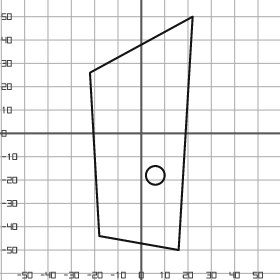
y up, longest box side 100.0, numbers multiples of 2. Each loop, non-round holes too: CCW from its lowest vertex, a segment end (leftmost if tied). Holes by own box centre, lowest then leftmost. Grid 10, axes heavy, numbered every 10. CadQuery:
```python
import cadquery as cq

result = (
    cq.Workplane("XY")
    .moveTo(16.0, -50.0)
    .lineTo(22.0, 50.0)
    .lineTo(-22.0, 26.0)
    .lineTo(-18.0, -44.0)
    .close()
    .moveTo(6.0, -18.0)
    .circle(4.0)
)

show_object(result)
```